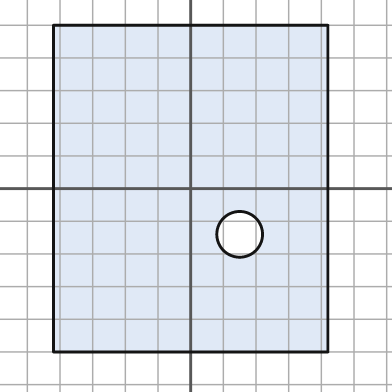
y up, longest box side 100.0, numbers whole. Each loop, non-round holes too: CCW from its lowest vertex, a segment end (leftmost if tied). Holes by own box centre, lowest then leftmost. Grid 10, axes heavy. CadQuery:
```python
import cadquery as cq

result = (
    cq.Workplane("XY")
    .moveTo(-42.0, -50.0)
    .lineTo(42.0, -50.0)
    .lineTo(42.0, 50.0)
    .lineTo(-42.0, 50.0)
    .close()
    .moveTo(15.0, -14.0)
    .circle(7.0)
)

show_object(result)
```